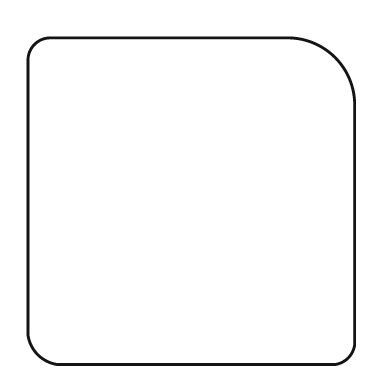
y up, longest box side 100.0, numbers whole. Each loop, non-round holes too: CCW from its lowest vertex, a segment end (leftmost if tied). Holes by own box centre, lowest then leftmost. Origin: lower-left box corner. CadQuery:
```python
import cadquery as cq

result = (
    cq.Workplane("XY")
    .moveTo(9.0, 0.0)
    .lineTo(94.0, 0.0)
    .threePointArc((98.0, 2.0), (100.0, 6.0))
    .lineTo(100.0, 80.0)
    .threePointArc((94.0, 94.0), (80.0, 100.0))
    .lineTo(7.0, 100.0)
    .threePointArc((2.0, 98.0), (0.0, 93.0))
    .lineTo(0.0, 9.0)
    .threePointArc((3.0, 3.0), (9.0, 0.0))
    .close()
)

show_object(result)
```